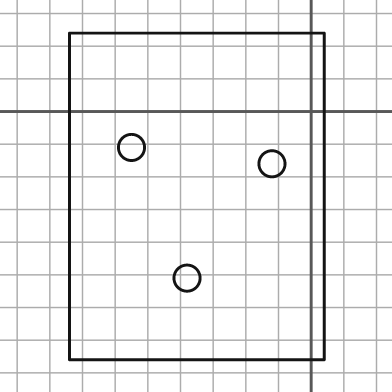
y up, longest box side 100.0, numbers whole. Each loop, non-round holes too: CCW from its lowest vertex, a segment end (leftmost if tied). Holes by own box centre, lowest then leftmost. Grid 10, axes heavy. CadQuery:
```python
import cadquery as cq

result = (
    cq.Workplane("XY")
    .moveTo(-74.0, -76.0)
    .lineTo(4.0, -76.0)
    .lineTo(4.0, 24.0)
    .lineTo(-74.0, 24.0)
    .close()
    .moveTo(-38.0, -51.0)
    .circle(4.0)
    .moveTo(-12.0, -16.0)
    .circle(4.0)
    .moveTo(-55.0, -11.0)
    .circle(4.0)
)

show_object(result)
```